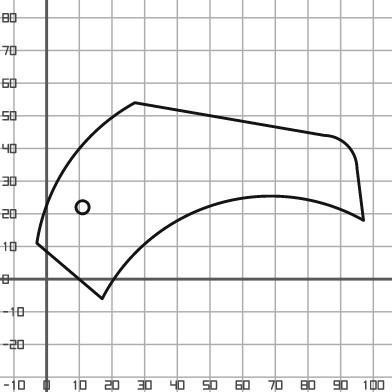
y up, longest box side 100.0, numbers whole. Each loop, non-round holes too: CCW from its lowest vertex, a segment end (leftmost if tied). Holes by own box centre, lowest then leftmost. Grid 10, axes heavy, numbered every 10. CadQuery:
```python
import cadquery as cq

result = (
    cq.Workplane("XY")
    .moveTo(17.0, -6.0)
    .threePointArc((52.0, 23.0), (97.0, 18.0))
    .lineTo(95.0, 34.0)
    .threePointArc((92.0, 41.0), (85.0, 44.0))
    .lineTo(27.0, 54.0)
    .threePointArc((7.0, 36.0), (-3.0, 11.0))
    .close()
    .moveTo(11.0, 22.0)
    .circle(2.0)
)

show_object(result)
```